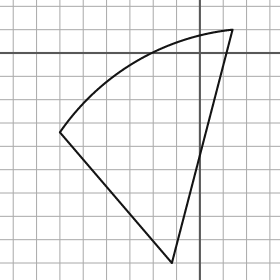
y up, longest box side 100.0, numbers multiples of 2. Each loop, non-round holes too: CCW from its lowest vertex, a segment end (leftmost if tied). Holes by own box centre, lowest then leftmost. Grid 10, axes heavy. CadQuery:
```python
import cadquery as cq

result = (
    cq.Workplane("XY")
    .moveTo(-12.0, -90.0)
    .lineTo(14.0, 10.0)
    .threePointArc((-28.0, -4.0), (-60.0, -34.0))
    .close()
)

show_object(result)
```